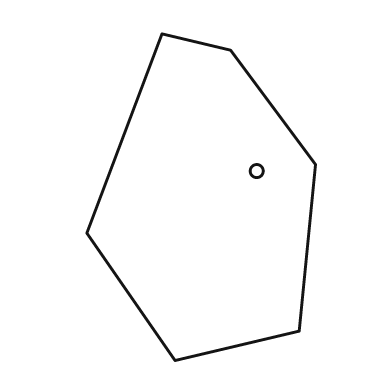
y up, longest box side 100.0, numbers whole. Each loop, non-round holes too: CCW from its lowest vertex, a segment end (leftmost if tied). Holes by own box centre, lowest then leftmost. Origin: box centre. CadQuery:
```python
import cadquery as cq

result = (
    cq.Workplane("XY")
    .moveTo(-8.0, -50.0)
    .lineTo(30.0, -41.0)
    .lineTo(35.0, 10.0)
    .lineTo(9.0, 45.0)
    .lineTo(-12.0, 50.0)
    .lineTo(-35.0, -11.0)
    .close()
    .moveTo(17.0, 8.0)
    .circle(2.0)
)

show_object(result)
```